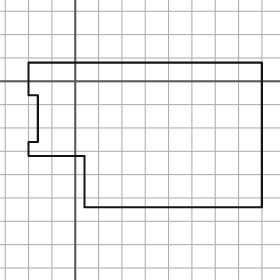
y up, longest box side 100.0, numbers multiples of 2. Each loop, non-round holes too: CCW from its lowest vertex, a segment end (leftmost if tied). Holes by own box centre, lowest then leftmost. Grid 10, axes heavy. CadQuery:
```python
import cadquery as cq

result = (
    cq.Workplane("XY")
    .moveTo(4.0, -54.0)
    .lineTo(80.0, -54.0)
    .lineTo(80.0, 8.0)
    .lineTo(-20.0, 8.0)
    .lineTo(-20.0, -6.0)
    .lineTo(-16.0, -6.0)
    .lineTo(-16.0, -26.0)
    .lineTo(-20.0, -26.0)
    .lineTo(-20.0, -32.0)
    .lineTo(4.0, -32.0)
    .close()
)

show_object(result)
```